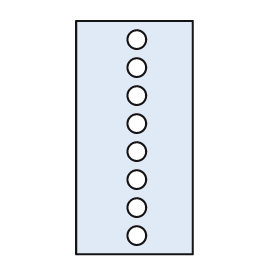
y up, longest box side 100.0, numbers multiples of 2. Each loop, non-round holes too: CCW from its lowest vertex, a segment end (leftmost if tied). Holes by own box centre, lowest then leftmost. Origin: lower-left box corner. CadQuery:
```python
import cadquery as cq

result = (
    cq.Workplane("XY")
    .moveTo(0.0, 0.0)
    .lineTo(50.0, 0.0)
    .lineTo(50.0, 100.0)
    .lineTo(0.0, 100.0)
    .close()
    .moveTo(26.0, 8.0)
    .circle(4.0)
    .moveTo(26.0, 20.0)
    .circle(4.0)
    .moveTo(26.0, 32.0)
    .circle(4.0)
    .moveTo(26.0, 44.0)
    .circle(4.0)
    .moveTo(26.0, 56.0)
    .circle(4.0)
    .moveTo(26.0, 68.0)
    .circle(4.0)
    .moveTo(26.0, 80.0)
    .circle(4.0)
    .moveTo(26.0, 92.0)
    .circle(4.0)
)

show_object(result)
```